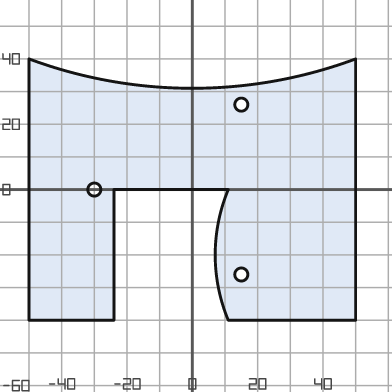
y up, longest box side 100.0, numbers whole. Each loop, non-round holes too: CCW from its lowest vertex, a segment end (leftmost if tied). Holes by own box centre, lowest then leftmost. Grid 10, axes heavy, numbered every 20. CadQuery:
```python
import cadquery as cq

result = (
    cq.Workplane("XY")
    .moveTo(-50.0, -40.0)
    .lineTo(-24.0, -40.0)
    .lineTo(-24.0, 0.0)
    .lineTo(11.0, 0.0)
    .threePointArc((7.0, -20.0), (11.0, -40.0))
    .lineTo(50.0, -40.0)
    .lineTo(50.0, 40.0)
    .threePointArc((0.0, 31.0), (-50.0, 40.0))
    .close()
    .moveTo(15.0, -26.0)
    .circle(2.0)
    .moveTo(-30.0, 0.0)
    .circle(2.0)
    .moveTo(15.0, 26.0)
    .circle(2.0)
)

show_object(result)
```